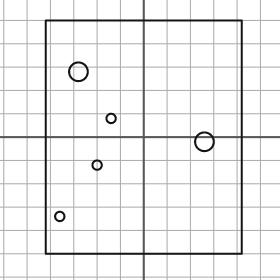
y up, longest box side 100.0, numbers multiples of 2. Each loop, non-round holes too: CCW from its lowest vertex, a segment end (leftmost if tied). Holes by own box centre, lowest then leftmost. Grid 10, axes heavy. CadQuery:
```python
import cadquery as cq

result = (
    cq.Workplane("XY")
    .moveTo(-42.0, -50.0)
    .lineTo(42.0, -50.0)
    .lineTo(42.0, 50.0)
    .lineTo(-42.0, 50.0)
    .close()
    .moveTo(-36.0, -34.0)
    .circle(2.0)
    .moveTo(-20.0, -12.0)
    .circle(2.0)
    .moveTo(26.0, -2.0)
    .circle(4.0)
    .moveTo(-14.0, 8.0)
    .circle(2.0)
    .moveTo(-28.0, 28.0)
    .circle(4.0)
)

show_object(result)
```